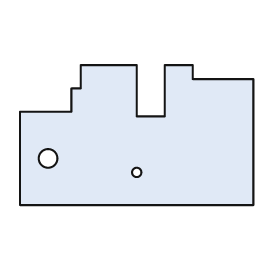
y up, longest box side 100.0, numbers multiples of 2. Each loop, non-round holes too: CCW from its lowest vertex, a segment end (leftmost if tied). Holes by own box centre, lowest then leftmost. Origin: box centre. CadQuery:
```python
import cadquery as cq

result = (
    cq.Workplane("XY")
    .moveTo(-50.0, -30.0)
    .lineTo(50.0, -30.0)
    .lineTo(50.0, 24.0)
    .lineTo(24.0, 24.0)
    .lineTo(24.0, 30.0)
    .lineTo(12.0, 30.0)
    .lineTo(12.0, 8.0)
    .lineTo(0.0, 8.0)
    .lineTo(0.0, 30.0)
    .lineTo(-24.0, 30.0)
    .lineTo(-24.0, 20.0)
    .lineTo(-28.0, 20.0)
    .lineTo(-28.0, 10.0)
    .lineTo(-50.0, 10.0)
    .close()
    .moveTo(0.0, -16.0)
    .circle(2.0)
    .moveTo(-38.0, -10.0)
    .circle(4.0)
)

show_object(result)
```